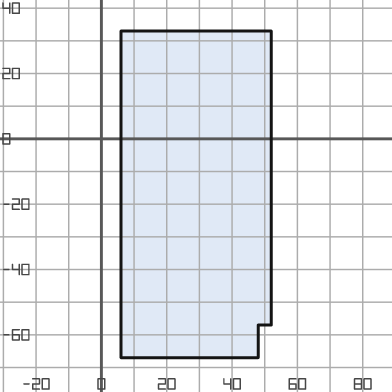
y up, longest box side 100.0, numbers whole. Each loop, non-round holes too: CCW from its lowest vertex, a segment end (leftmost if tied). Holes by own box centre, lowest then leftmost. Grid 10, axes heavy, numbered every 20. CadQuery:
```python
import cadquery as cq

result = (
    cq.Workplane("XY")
    .moveTo(6.0, -67.0)
    .lineTo(48.0, -67.0)
    .lineTo(48.0, -57.0)
    .lineTo(52.0, -57.0)
    .lineTo(52.0, 33.0)
    .lineTo(6.0, 33.0)
    .close()
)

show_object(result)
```